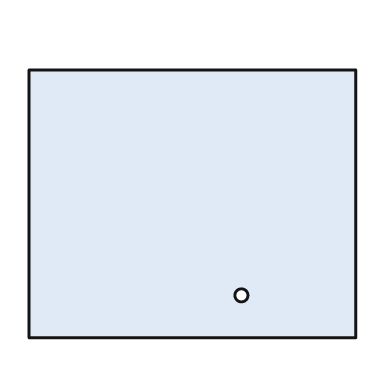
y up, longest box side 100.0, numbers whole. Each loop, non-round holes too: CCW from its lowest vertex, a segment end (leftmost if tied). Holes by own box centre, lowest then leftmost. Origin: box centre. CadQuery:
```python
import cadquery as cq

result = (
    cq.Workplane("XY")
    .moveTo(-50.0, -41.0)
    .lineTo(50.0, -41.0)
    .lineTo(50.0, 41.0)
    .lineTo(-50.0, 41.0)
    .close()
    .moveTo(15.0, -28.0)
    .circle(2.0)
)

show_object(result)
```